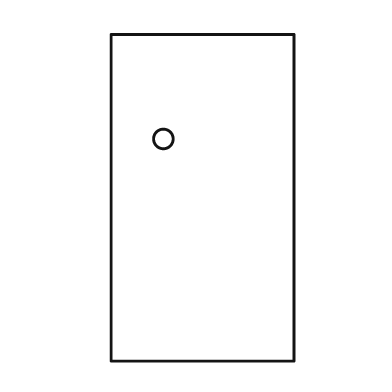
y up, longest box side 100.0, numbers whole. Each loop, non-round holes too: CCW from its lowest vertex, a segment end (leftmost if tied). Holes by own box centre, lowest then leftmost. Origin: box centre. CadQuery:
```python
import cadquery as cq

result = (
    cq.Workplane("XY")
    .moveTo(-28.0, -50.0)
    .lineTo(28.0, -50.0)
    .lineTo(28.0, 50.0)
    .lineTo(-28.0, 50.0)
    .close()
    .moveTo(-12.0, 18.0)
    .circle(3.0)
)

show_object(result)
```